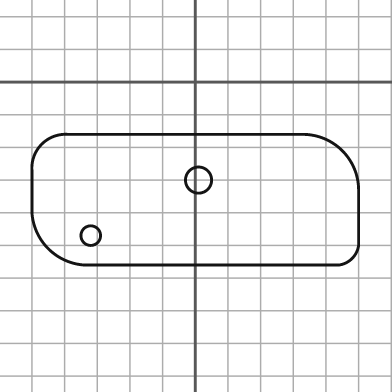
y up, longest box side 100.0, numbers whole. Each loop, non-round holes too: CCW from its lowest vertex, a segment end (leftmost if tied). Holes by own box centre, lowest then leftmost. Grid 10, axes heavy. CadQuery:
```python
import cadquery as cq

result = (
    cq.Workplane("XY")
    .moveTo(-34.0, -56.0)
    .lineTo(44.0, -56.0)
    .threePointArc((48.0, -54.0), (50.0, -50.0))
    .lineTo(50.0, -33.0)
    .threePointArc((45.0, -21.0), (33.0, -16.0))
    .lineTo(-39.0, -16.0)
    .threePointArc((-47.0, -19.0), (-50.0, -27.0))
    .lineTo(-50.0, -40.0)
    .threePointArc((-45.0, -51.0), (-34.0, -56.0))
    .close()
    .moveTo(-32.0, -47.0)
    .circle(3.0)
    .moveTo(1.0, -30.0)
    .circle(4.0)
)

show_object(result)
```